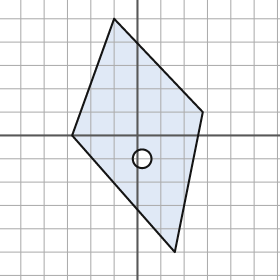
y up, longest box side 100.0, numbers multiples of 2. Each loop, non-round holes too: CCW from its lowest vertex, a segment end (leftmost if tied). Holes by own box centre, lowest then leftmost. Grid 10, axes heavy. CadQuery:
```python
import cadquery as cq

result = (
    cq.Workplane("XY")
    .moveTo(16.0, -50.0)
    .lineTo(28.0, 10.0)
    .lineTo(-10.0, 50.0)
    .lineTo(-28.0, 0.0)
    .close()
    .moveTo(2.0, -10.0)
    .circle(4.0)
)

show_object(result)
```